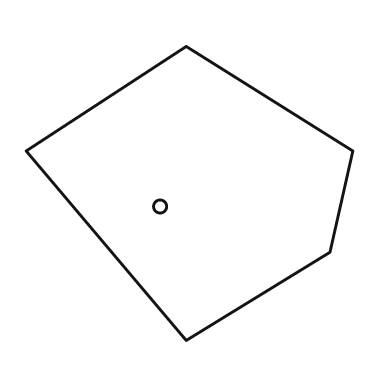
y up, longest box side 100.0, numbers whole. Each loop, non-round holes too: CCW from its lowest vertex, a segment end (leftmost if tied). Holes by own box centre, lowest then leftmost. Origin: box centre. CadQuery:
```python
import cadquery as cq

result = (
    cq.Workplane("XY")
    .moveTo(-1.0, -45.0)
    .lineTo(43.0, -18.0)
    .lineTo(50.0, 13.0)
    .lineTo(-1.0, 45.0)
    .lineTo(-50.0, 13.0)
    .close()
    .moveTo(-9.0, -4.0)
    .circle(2.0)
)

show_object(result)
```